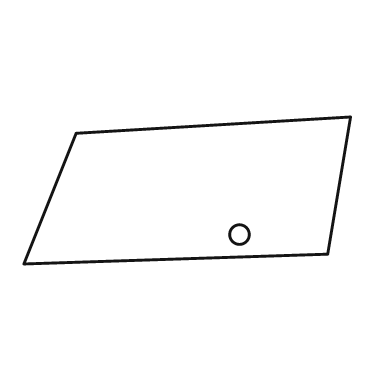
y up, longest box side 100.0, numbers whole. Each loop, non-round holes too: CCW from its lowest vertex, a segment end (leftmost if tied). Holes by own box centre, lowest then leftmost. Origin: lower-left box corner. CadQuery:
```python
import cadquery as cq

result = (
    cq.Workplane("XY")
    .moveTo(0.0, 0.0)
    .lineTo(93.0, 3.0)
    .lineTo(100.0, 45.0)
    .lineTo(16.0, 40.0)
    .close()
    .moveTo(66.0, 9.0)
    .circle(3.0)
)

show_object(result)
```